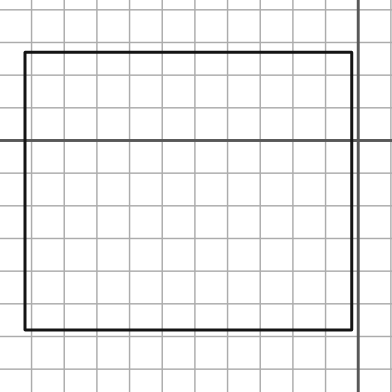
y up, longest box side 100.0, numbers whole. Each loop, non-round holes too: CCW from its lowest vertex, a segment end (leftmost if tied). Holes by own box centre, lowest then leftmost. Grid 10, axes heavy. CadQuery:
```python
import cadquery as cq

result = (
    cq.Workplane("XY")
    .moveTo(-102.0, -58.0)
    .lineTo(-2.0, -58.0)
    .lineTo(-2.0, 27.0)
    .lineTo(-102.0, 27.0)
    .close()
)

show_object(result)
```